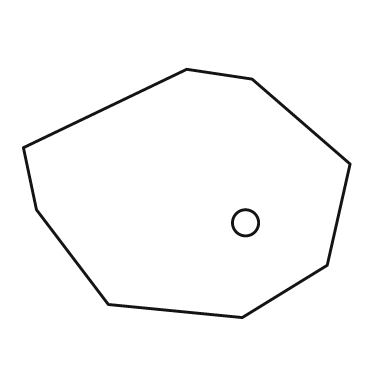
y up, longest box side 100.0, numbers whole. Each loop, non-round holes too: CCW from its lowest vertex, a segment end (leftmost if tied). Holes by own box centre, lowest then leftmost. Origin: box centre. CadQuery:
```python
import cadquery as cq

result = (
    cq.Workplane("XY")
    .moveTo(17.0, -38.0)
    .lineTo(43.0, -22.0)
    .lineTo(50.0, 9.0)
    .lineTo(20.0, 35.0)
    .lineTo(0.0, 38.0)
    .lineTo(-50.0, 14.0)
    .lineTo(-46.0, -5.0)
    .lineTo(-24.0, -34.0)
    .close()
    .moveTo(18.0, -9.0)
    .circle(4.0)
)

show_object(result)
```